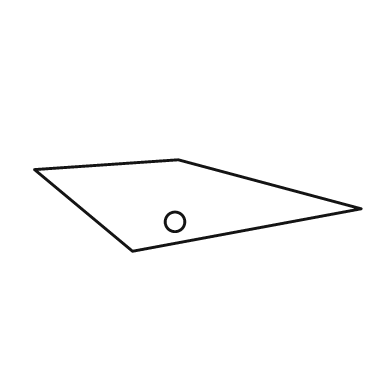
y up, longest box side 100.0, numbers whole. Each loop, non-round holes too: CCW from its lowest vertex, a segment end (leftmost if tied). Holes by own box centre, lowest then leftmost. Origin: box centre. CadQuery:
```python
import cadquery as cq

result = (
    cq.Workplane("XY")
    .moveTo(-20.0, -14.0)
    .lineTo(50.0, -1.0)
    .lineTo(-6.0, 14.0)
    .lineTo(-50.0, 11.0)
    .close()
    .moveTo(-7.0, -5.0)
    .circle(3.0)
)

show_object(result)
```